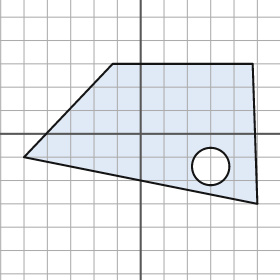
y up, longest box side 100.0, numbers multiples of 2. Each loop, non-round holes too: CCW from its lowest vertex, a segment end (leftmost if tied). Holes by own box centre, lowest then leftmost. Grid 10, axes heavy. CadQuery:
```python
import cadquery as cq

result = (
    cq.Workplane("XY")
    .moveTo(50.0, -30.0)
    .lineTo(48.0, 30.0)
    .lineTo(-12.0, 30.0)
    .lineTo(-50.0, -10.0)
    .close()
    .moveTo(30.0, -14.0)
    .circle(8.0)
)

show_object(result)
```